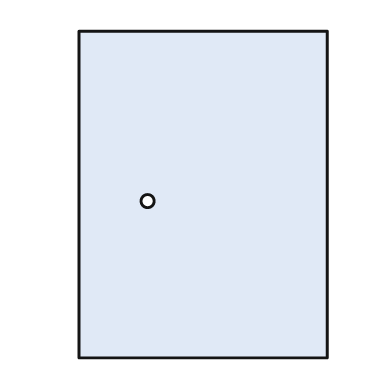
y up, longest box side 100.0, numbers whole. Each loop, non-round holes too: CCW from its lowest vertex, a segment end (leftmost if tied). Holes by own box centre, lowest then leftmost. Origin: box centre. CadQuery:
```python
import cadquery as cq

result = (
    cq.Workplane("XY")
    .moveTo(-38.0, -50.0)
    .lineTo(38.0, -50.0)
    .lineTo(38.0, 50.0)
    .lineTo(-38.0, 50.0)
    .close()
    .moveTo(-17.0, -2.0)
    .circle(2.0)
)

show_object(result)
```